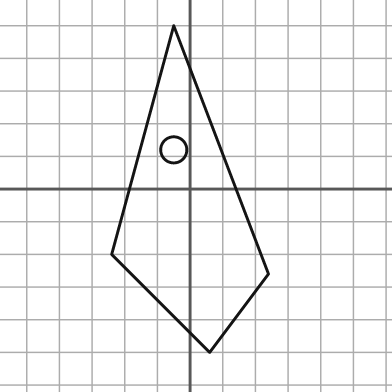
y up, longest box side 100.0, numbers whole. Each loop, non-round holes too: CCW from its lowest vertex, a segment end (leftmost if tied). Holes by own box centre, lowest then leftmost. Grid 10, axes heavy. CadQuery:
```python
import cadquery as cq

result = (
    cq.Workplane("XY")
    .moveTo(6.0, -50.0)
    .lineTo(24.0, -26.0)
    .lineTo(-5.0, 50.0)
    .lineTo(-24.0, -20.0)
    .close()
    .moveTo(-5.0, 12.0)
    .circle(4.0)
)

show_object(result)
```